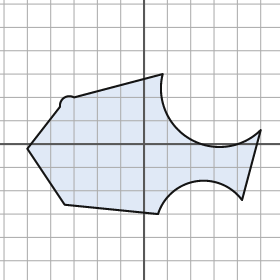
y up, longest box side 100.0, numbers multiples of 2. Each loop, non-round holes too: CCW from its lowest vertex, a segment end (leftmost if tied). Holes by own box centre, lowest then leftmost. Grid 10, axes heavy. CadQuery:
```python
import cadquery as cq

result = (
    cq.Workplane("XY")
    .moveTo(6.0, -30.0)
    .threePointArc((22.0, -16.0), (42.0, -24.0))
    .lineTo(50.0, 6.0)
    .threePointArc((20.0, 2.0), (8.0, 30.0))
    .lineTo(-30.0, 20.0)
    .threePointArc((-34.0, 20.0), (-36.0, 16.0))
    .lineTo(-50.0, -2.0)
    .lineTo(-34.0, -26.0)
    .close()
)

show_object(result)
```